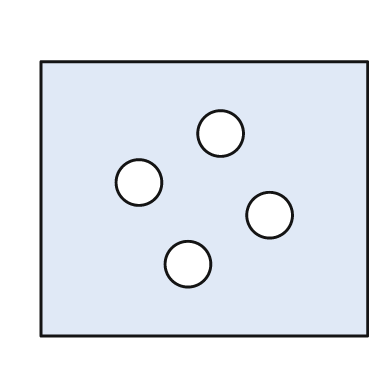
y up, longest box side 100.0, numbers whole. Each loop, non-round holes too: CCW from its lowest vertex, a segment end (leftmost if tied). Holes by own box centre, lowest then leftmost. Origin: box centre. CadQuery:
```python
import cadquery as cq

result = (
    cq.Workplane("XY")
    .moveTo(-50.0, -42.0)
    .lineTo(50.0, -42.0)
    .lineTo(50.0, 42.0)
    .lineTo(-50.0, 42.0)
    .close()
    .moveTo(-5.0, -20.0)
    .circle(7.0)
    .moveTo(20.0, -5.0)
    .circle(7.0)
    .moveTo(-20.0, 5.0)
    .circle(7.0)
    .moveTo(5.0, 20.0)
    .circle(7.0)
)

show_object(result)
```